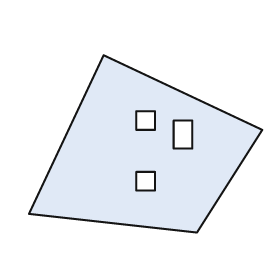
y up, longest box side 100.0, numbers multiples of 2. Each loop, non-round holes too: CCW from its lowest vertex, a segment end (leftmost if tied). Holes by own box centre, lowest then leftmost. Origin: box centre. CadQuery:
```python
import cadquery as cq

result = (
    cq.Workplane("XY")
    .moveTo(22.0, -38.0)
    .lineTo(50.0, 6.0)
    .lineTo(-18.0, 38.0)
    .lineTo(-50.0, -30.0)
    .close()
    .moveTo(-4.0, -20.0)
    .lineTo(4.0, -20.0)
    .lineTo(4.0, -12.0)
    .lineTo(-4.0, -12.0)
    .close()
    .moveTo(12.0, -2.0)
    .lineTo(20.0, -2.0)
    .lineTo(20.0, 10.0)
    .lineTo(12.0, 10.0)
    .close()
    .moveTo(-4.0, 6.0)
    .lineTo(4.0, 6.0)
    .lineTo(4.0, 14.0)
    .lineTo(-4.0, 14.0)
    .close()
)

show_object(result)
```